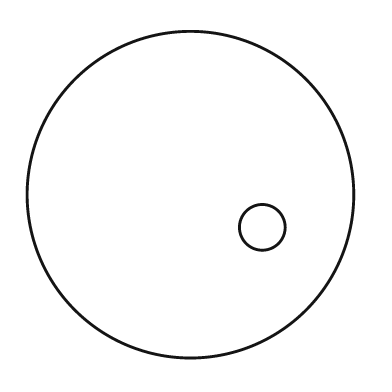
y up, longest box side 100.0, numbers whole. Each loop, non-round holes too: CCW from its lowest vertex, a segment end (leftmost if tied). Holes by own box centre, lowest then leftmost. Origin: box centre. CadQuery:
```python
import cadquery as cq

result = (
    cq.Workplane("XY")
    .moveTo(0.0, 0.0)
    .circle(50.0)
    .moveTo(22.0, -10.0)
    .circle(7.0)
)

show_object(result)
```